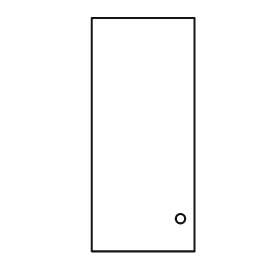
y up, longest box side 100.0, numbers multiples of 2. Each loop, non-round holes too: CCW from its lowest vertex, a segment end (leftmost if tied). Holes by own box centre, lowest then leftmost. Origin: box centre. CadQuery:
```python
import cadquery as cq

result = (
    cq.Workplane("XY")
    .moveTo(-22.0, -50.0)
    .lineTo(22.0, -50.0)
    .lineTo(22.0, 50.0)
    .lineTo(-22.0, 50.0)
    .close()
    .moveTo(16.0, -36.0)
    .circle(2.0)
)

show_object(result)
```